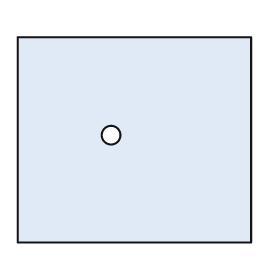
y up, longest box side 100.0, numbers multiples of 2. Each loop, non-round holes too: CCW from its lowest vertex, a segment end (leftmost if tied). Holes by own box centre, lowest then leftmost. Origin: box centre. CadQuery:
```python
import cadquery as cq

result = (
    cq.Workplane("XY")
    .moveTo(-50.0, -44.0)
    .lineTo(50.0, -44.0)
    .lineTo(50.0, 44.0)
    .lineTo(-50.0, 44.0)
    .close()
    .moveTo(-10.0, 2.0)
    .circle(4.0)
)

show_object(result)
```